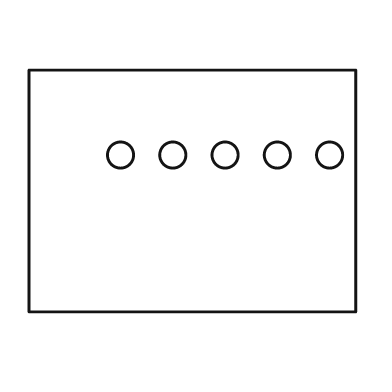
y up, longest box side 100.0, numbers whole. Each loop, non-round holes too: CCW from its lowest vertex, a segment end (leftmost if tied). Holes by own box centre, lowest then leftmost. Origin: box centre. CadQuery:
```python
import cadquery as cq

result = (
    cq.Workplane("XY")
    .moveTo(-50.0, -37.0)
    .lineTo(50.0, -37.0)
    .lineTo(50.0, 37.0)
    .lineTo(-50.0, 37.0)
    .close()
    .moveTo(-22.0, 11.0)
    .circle(4.0)
    .moveTo(-6.0, 11.0)
    .circle(4.0)
    .moveTo(10.0, 11.0)
    .circle(4.0)
    .moveTo(26.0, 11.0)
    .circle(4.0)
    .moveTo(42.0, 11.0)
    .circle(4.0)
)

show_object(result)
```